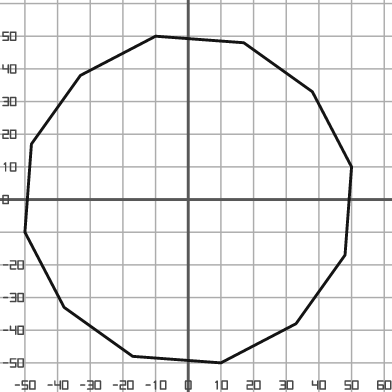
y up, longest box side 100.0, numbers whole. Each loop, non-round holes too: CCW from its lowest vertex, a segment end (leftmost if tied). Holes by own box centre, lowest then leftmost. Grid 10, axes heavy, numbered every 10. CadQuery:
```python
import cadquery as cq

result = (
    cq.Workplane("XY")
    .moveTo(10.0, -50.0)
    .lineTo(33.0, -38.0)
    .lineTo(48.0, -17.0)
    .lineTo(50.0, 10.0)
    .lineTo(38.0, 33.0)
    .lineTo(17.0, 48.0)
    .lineTo(-10.0, 50.0)
    .lineTo(-33.0, 38.0)
    .lineTo(-48.0, 17.0)
    .lineTo(-50.0, -10.0)
    .lineTo(-38.0, -33.0)
    .lineTo(-17.0, -48.0)
    .close()
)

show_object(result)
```